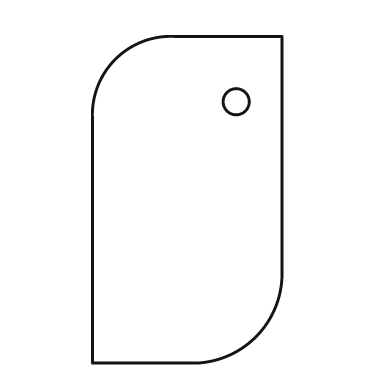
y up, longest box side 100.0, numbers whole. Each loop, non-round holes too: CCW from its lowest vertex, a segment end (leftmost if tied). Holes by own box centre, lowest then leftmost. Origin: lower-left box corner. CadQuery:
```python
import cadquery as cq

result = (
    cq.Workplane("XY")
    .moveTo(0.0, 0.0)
    .lineTo(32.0, 0.0)
    .threePointArc((50.0, 8.0), (58.0, 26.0))
    .lineTo(58.0, 100.0)
    .lineTo(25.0, 100.0)
    .threePointArc((7.0, 93.0), (0.0, 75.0))
    .close()
    .moveTo(44.0, 80.0)
    .circle(4.0)
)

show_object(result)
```